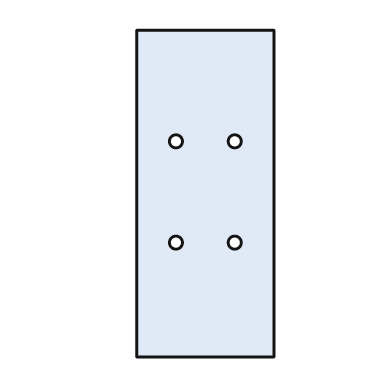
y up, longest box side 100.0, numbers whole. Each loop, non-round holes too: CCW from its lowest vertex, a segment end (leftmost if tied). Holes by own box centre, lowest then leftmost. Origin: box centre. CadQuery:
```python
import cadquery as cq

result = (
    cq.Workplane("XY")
    .moveTo(-21.0, -50.0)
    .lineTo(21.0, -50.0)
    .lineTo(21.0, 50.0)
    .lineTo(-21.0, 50.0)
    .close()
    .moveTo(-9.0, -15.0)
    .circle(2.0)
    .moveTo(9.0, -15.0)
    .circle(2.0)
    .moveTo(-9.0, 16.0)
    .circle(2.0)
    .moveTo(9.0, 16.0)
    .circle(2.0)
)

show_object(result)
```